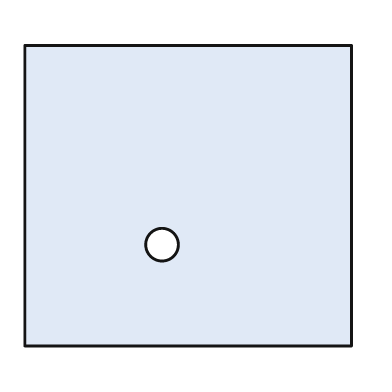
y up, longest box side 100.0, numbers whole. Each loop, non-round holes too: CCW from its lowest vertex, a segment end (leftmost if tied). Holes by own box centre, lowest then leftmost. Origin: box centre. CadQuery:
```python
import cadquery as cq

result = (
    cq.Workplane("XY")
    .moveTo(-50.0, -46.0)
    .lineTo(50.0, -46.0)
    .lineTo(50.0, 46.0)
    .lineTo(-50.0, 46.0)
    .close()
    .moveTo(-8.0, -15.0)
    .circle(5.0)
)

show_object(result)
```